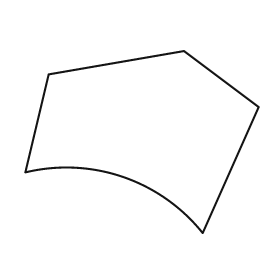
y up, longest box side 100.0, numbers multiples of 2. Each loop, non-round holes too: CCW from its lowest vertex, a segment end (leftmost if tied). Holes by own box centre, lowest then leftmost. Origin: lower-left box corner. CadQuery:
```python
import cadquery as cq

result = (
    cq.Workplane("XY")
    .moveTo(76.0, 0.0)
    .lineTo(100.0, 54.0)
    .lineTo(68.0, 78.0)
    .lineTo(10.0, 68.0)
    .lineTo(0.0, 26.0)
    .threePointArc((42.0, 24.0), (76.0, 0.0))
    .close()
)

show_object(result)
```